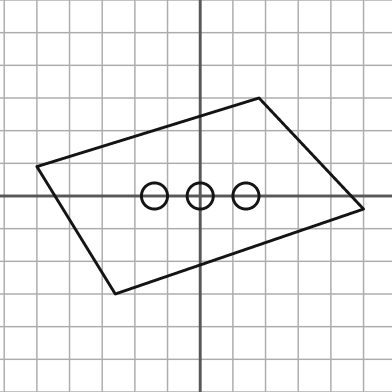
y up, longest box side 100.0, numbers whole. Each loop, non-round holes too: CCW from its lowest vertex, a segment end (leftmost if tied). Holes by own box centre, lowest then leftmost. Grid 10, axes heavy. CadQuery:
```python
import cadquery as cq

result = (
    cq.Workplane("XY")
    .moveTo(-26.0, -30.0)
    .lineTo(50.0, -4.0)
    .lineTo(18.0, 30.0)
    .lineTo(-50.0, 9.0)
    .close()
    .moveTo(-14.0, 0.0)
    .circle(4.0)
    .moveTo(0.0, 0.0)
    .circle(4.0)
    .moveTo(14.0, 0.0)
    .circle(4.0)
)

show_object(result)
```